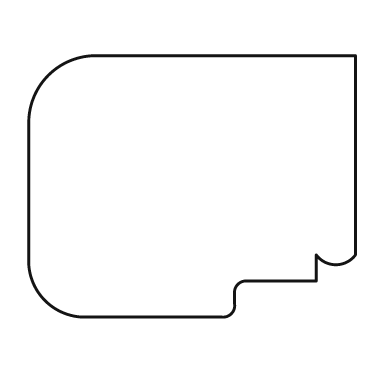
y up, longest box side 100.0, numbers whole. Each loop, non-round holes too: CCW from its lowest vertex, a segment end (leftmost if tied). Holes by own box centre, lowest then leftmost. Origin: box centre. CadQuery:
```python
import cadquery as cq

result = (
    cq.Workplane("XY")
    .moveTo(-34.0, -40.0)
    .lineTo(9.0, -40.0)
    .threePointArc((12.0, -39.0), (13.0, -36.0))
    .lineTo(13.0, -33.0)
    .threePointArc((14.0, -30.0), (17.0, -29.0))
    .lineTo(38.0, -29.0)
    .lineTo(38.0, -21.0)
    .threePointArc((44.0, -24.0), (50.0, -21.0))
    .lineTo(50.0, 40.0)
    .lineTo(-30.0, 40.0)
    .threePointArc((-44.0, 34.0), (-50.0, 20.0))
    .lineTo(-50.0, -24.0)
    .threePointArc((-45.0, -35.0), (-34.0, -40.0))
    .close()
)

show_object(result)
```